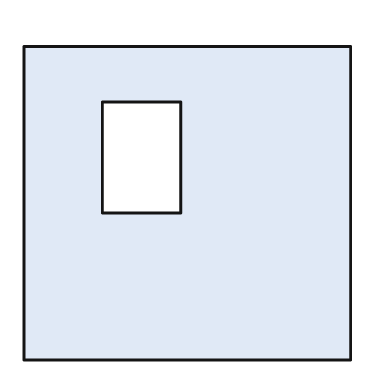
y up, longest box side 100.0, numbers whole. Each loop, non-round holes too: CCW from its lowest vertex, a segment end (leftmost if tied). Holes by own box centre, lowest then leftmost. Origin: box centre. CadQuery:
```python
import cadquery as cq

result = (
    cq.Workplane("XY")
    .moveTo(-50.0, -48.0)
    .lineTo(50.0, -48.0)
    .lineTo(50.0, 48.0)
    .lineTo(-50.0, 48.0)
    .close()
    .moveTo(-26.0, -3.0)
    .lineTo(-2.0, -3.0)
    .lineTo(-2.0, 31.0)
    .lineTo(-26.0, 31.0)
    .close()
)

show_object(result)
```